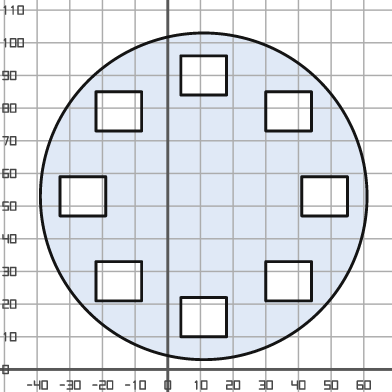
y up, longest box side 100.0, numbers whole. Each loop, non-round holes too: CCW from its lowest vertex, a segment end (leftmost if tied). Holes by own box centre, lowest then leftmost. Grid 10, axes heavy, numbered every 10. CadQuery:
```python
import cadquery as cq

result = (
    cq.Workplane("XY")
    .moveTo(11.0, 53.0)
    .circle(50.0)
    .moveTo(4.0, 10.0)
    .lineTo(18.0, 10.0)
    .lineTo(18.0, 22.0)
    .lineTo(4.0, 22.0)
    .close()
    .moveTo(-22.0, 21.0)
    .lineTo(-8.0, 21.0)
    .lineTo(-8.0, 33.0)
    .lineTo(-22.0, 33.0)
    .close()
    .moveTo(30.0, 21.0)
    .lineTo(44.0, 21.0)
    .lineTo(44.0, 33.0)
    .lineTo(30.0, 33.0)
    .close()
    .moveTo(-33.0, 47.0)
    .lineTo(-19.0, 47.0)
    .lineTo(-19.0, 59.0)
    .lineTo(-33.0, 59.0)
    .close()
    .moveTo(41.0, 47.0)
    .lineTo(55.0, 47.0)
    .lineTo(55.0, 59.0)
    .lineTo(41.0, 59.0)
    .close()
    .moveTo(-22.0, 73.0)
    .lineTo(-8.0, 73.0)
    .lineTo(-8.0, 85.0)
    .lineTo(-22.0, 85.0)
    .close()
    .moveTo(30.0, 73.0)
    .lineTo(44.0, 73.0)
    .lineTo(44.0, 85.0)
    .lineTo(30.0, 85.0)
    .close()
    .moveTo(4.0, 84.0)
    .lineTo(18.0, 84.0)
    .lineTo(18.0, 96.0)
    .lineTo(4.0, 96.0)
    .close()
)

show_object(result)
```